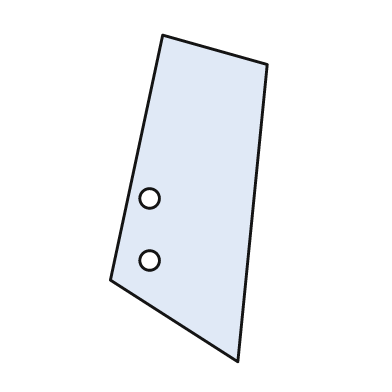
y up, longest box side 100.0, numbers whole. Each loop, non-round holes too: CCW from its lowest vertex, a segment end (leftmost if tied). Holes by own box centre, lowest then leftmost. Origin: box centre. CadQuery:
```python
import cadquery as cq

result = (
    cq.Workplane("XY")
    .moveTo(15.0, -50.0)
    .lineTo(24.0, 41.0)
    .lineTo(-8.0, 50.0)
    .lineTo(-24.0, -25.0)
    .close()
    .moveTo(-12.0, -19.0)
    .circle(3.0)
    .moveTo(-12.0, 0.0)
    .circle(3.0)
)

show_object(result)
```